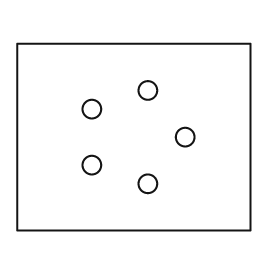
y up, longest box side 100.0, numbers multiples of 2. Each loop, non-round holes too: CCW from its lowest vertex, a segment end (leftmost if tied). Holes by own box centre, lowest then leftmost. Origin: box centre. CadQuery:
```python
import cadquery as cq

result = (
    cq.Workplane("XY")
    .moveTo(-50.0, -40.0)
    .lineTo(50.0, -40.0)
    .lineTo(50.0, 40.0)
    .lineTo(-50.0, 40.0)
    .close()
    .moveTo(6.0, -20.0)
    .circle(4.0)
    .moveTo(-18.0, -12.0)
    .circle(4.0)
    .moveTo(22.0, 0.0)
    .circle(4.0)
    .moveTo(-18.0, 12.0)
    .circle(4.0)
    .moveTo(6.0, 20.0)
    .circle(4.0)
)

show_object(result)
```